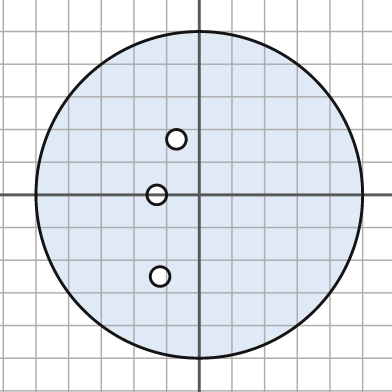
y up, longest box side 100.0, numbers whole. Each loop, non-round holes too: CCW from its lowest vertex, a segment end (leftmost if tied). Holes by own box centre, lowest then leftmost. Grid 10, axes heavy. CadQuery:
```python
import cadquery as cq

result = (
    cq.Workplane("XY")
    .moveTo(0.0, 0.0)
    .circle(50.0)
    .moveTo(-12.0, -25.0)
    .circle(3.0)
    .moveTo(-13.0, 0.0)
    .circle(3.0)
    .moveTo(-7.0, 17.0)
    .circle(3.0)
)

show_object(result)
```